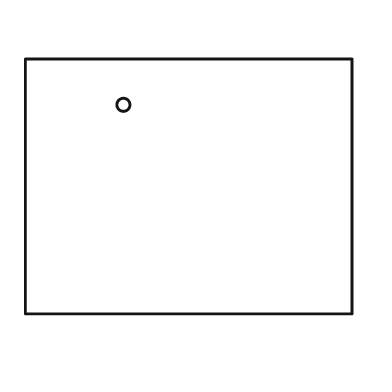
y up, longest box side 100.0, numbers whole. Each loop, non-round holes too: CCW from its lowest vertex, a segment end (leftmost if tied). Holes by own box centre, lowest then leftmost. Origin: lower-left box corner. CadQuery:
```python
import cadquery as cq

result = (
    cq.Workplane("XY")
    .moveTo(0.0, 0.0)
    .lineTo(100.0, 0.0)
    .lineTo(100.0, 78.0)
    .lineTo(0.0, 78.0)
    .close()
    .moveTo(30.0, 64.0)
    .circle(2.0)
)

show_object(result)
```